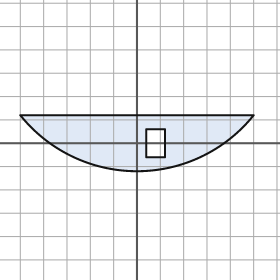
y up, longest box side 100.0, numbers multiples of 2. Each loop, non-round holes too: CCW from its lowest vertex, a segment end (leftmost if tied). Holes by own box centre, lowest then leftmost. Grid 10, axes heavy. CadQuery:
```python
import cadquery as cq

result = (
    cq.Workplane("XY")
    .moveTo(-50.0, 12.0)
    .threePointArc((0.0, -12.0), (50.0, 12.0))
    .close()
    .moveTo(4.0, -6.0)
    .lineTo(12.0, -6.0)
    .lineTo(12.0, 6.0)
    .lineTo(4.0, 6.0)
    .close()
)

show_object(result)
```